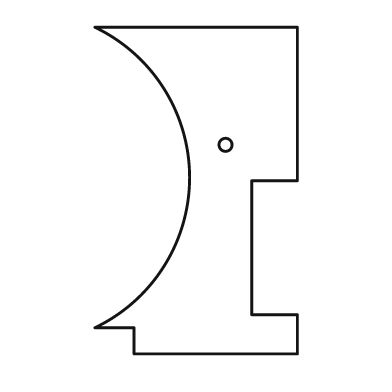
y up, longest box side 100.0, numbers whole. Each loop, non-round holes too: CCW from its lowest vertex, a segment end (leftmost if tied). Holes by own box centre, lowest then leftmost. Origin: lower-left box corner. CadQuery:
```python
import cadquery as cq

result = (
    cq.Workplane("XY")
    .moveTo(12.0, 0.0)
    .lineTo(62.0, 0.0)
    .lineTo(62.0, 12.0)
    .lineTo(48.0, 12.0)
    .lineTo(48.0, 53.0)
    .lineTo(62.0, 53.0)
    .lineTo(62.0, 100.0)
    .lineTo(0.0, 100.0)
    .threePointArc((29.0, 54.0), (0.0, 8.0))
    .lineTo(12.0, 8.0)
    .close()
    .moveTo(40.0, 64.0)
    .circle(2.0)
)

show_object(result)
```